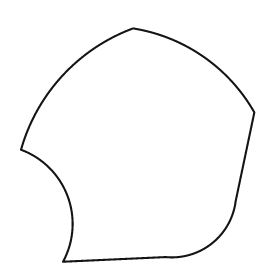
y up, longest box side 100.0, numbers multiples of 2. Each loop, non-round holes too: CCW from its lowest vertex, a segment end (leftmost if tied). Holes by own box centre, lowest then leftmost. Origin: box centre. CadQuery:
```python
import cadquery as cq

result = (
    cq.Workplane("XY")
    .moveTo(-32.0, -50.0)
    .lineTo(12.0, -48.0)
    .threePointArc((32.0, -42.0), (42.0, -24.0))
    .lineTo(50.0, 14.0)
    .threePointArc((28.0, 38.0), (-2.0, 50.0))
    .threePointArc((-32.0, 30.0), (-50.0, -2.0))
    .threePointArc((-30.0, -22.0), (-32.0, -50.0))
    .close()
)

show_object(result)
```